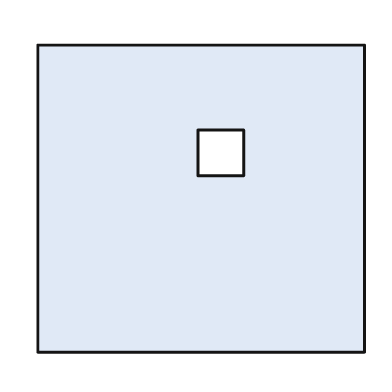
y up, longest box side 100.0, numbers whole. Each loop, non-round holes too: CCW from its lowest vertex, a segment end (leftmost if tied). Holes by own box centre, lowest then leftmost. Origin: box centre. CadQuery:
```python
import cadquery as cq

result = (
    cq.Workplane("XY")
    .moveTo(-50.0, -47.0)
    .lineTo(50.0, -47.0)
    .lineTo(50.0, 47.0)
    .lineTo(-50.0, 47.0)
    .close()
    .moveTo(-1.0, 7.0)
    .lineTo(13.0, 7.0)
    .lineTo(13.0, 21.0)
    .lineTo(-1.0, 21.0)
    .close()
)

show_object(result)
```